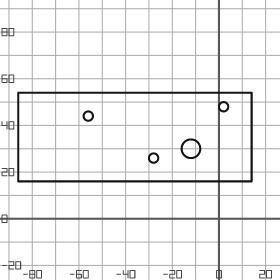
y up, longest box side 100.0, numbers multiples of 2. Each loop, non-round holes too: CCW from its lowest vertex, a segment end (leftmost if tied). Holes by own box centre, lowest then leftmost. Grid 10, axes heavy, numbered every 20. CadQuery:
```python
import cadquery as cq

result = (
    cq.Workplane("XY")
    .moveTo(-86.0, 16.0)
    .lineTo(14.0, 16.0)
    .lineTo(14.0, 54.0)
    .lineTo(-86.0, 54.0)
    .close()
    .moveTo(-28.0, 26.0)
    .circle(2.0)
    .moveTo(-12.0, 30.0)
    .circle(4.0)
    .moveTo(-56.0, 44.0)
    .circle(2.0)
    .moveTo(2.0, 48.0)
    .circle(2.0)
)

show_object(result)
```